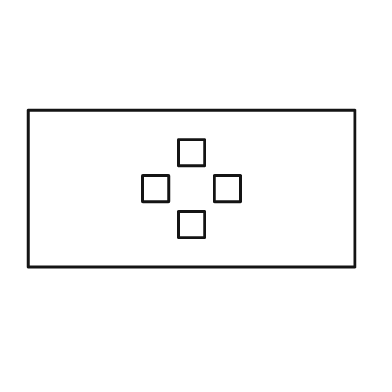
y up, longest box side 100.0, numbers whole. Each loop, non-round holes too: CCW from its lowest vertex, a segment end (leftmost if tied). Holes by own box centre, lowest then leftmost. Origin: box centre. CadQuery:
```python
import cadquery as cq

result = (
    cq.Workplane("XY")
    .moveTo(-50.0, -24.0)
    .lineTo(50.0, -24.0)
    .lineTo(50.0, 24.0)
    .lineTo(-50.0, 24.0)
    .close()
    .moveTo(-4.0, -15.0)
    .lineTo(4.0, -15.0)
    .lineTo(4.0, -7.0)
    .lineTo(-4.0, -7.0)
    .close()
    .moveTo(-15.0, -4.0)
    .lineTo(-7.0, -4.0)
    .lineTo(-7.0, 4.0)
    .lineTo(-15.0, 4.0)
    .close()
    .moveTo(7.0, -4.0)
    .lineTo(15.0, -4.0)
    .lineTo(15.0, 4.0)
    .lineTo(7.0, 4.0)
    .close()
    .moveTo(-4.0, 7.0)
    .lineTo(4.0, 7.0)
    .lineTo(4.0, 15.0)
    .lineTo(-4.0, 15.0)
    .close()
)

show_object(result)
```